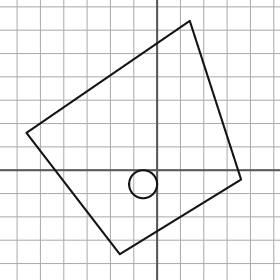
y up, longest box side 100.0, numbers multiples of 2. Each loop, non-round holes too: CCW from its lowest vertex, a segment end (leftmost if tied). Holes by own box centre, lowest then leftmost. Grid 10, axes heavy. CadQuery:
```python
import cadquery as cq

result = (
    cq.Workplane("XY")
    .moveTo(-16.0, -36.0)
    .lineTo(36.0, -4.0)
    .lineTo(14.0, 64.0)
    .lineTo(-56.0, 16.0)
    .close()
    .moveTo(-6.0, -6.0)
    .circle(6.0)
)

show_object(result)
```